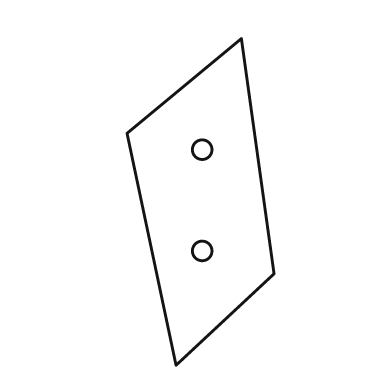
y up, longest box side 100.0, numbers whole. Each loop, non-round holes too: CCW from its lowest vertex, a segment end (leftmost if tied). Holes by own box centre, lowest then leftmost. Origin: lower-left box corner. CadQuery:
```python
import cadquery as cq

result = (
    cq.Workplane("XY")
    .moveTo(15.0, 0.0)
    .lineTo(45.0, 28.0)
    .lineTo(35.0, 100.0)
    .lineTo(0.0, 71.0)
    .close()
    .moveTo(23.0, 35.0)
    .circle(3.0)
    .moveTo(23.0, 66.0)
    .circle(3.0)
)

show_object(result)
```